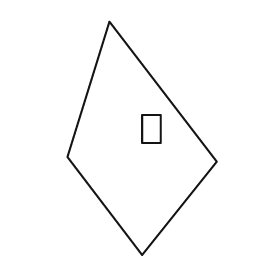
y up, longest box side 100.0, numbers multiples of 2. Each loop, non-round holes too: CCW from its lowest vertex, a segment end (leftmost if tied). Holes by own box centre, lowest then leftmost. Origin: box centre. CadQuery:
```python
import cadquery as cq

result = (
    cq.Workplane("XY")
    .moveTo(0.0, -50.0)
    .lineTo(32.0, -10.0)
    .lineTo(-14.0, 50.0)
    .lineTo(-32.0, -8.0)
    .close()
    .moveTo(0.0, -2.0)
    .lineTo(8.0, -2.0)
    .lineTo(8.0, 10.0)
    .lineTo(0.0, 10.0)
    .close()
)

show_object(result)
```